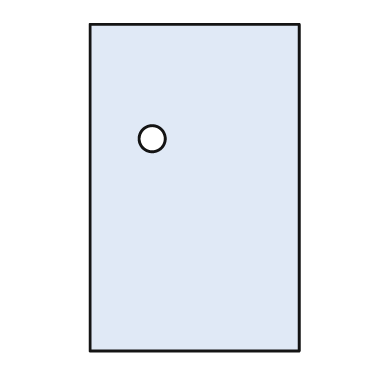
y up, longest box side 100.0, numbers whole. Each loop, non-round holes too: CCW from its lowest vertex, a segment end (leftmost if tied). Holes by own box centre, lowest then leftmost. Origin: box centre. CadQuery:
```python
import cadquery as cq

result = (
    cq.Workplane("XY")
    .moveTo(-32.0, -50.0)
    .lineTo(32.0, -50.0)
    .lineTo(32.0, 50.0)
    .lineTo(-32.0, 50.0)
    .close()
    .moveTo(-13.0, 15.0)
    .circle(4.0)
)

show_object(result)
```